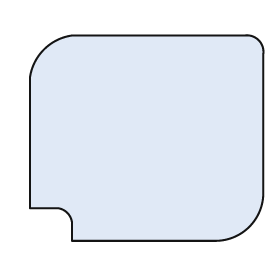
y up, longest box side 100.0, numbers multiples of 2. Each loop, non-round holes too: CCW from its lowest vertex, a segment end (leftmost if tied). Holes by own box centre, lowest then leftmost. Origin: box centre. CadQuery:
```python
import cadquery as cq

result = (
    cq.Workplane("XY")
    .moveTo(-32.0, -44.0)
    .lineTo(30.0, -44.0)
    .threePointArc((44.0, -38.0), (50.0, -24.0))
    .lineTo(50.0, 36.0)
    .threePointArc((48.0, 42.0), (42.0, 44.0))
    .lineTo(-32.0, 44.0)
    .threePointArc((-44.0, 38.0), (-50.0, 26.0))
    .lineTo(-50.0, -30.0)
    .lineTo(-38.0, -30.0)
    .threePointArc((-34.0, -32.0), (-32.0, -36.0))
    .close()
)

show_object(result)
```